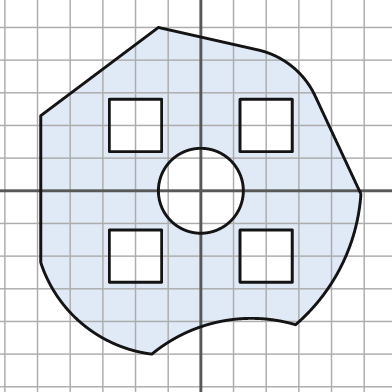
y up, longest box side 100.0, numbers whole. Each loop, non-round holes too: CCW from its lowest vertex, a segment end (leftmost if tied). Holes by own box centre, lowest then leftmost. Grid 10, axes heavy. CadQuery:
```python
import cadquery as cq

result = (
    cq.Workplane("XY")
    .moveTo(-15.0, -50.0)
    .threePointArc((6.0, -40.0), (29.0, -41.0))
    .threePointArc((43.0, -23.0), (49.0, -1.0))
    .lineTo(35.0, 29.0)
    .threePointArc((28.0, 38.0), (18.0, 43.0))
    .lineTo(-13.0, 50.0)
    .lineTo(-49.0, 23.0)
    .lineTo(-49.0, -22.0)
    .threePointArc((-36.0, -41.0), (-15.0, -50.0))
    .close()
    .moveTo(-28.0, -28.0)
    .lineTo(-12.0, -28.0)
    .lineTo(-12.0, -12.0)
    .lineTo(-28.0, -12.0)
    .close()
    .moveTo(12.0, -28.0)
    .lineTo(28.0, -28.0)
    .lineTo(28.0, -12.0)
    .lineTo(12.0, -12.0)
    .close()
    .moveTo(0.0, 0.0)
    .circle(13.0)
    .moveTo(-28.0, 12.0)
    .lineTo(-12.0, 12.0)
    .lineTo(-12.0, 28.0)
    .lineTo(-28.0, 28.0)
    .close()
    .moveTo(12.0, 12.0)
    .lineTo(28.0, 12.0)
    .lineTo(28.0, 28.0)
    .lineTo(12.0, 28.0)
    .close()
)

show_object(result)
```